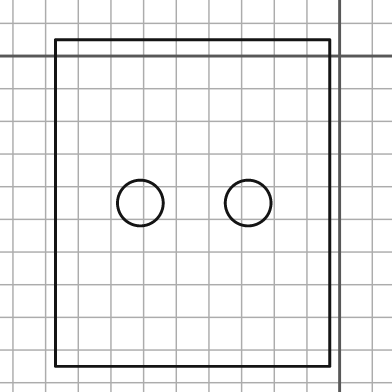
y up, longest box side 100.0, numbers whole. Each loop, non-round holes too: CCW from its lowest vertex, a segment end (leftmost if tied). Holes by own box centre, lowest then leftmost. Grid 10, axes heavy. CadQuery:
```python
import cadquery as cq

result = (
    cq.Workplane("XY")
    .moveTo(-87.0, -95.0)
    .lineTo(-3.0, -95.0)
    .lineTo(-3.0, 5.0)
    .lineTo(-87.0, 5.0)
    .close()
    .moveTo(-61.0, -45.0)
    .circle(7.0)
    .moveTo(-28.0, -45.0)
    .circle(7.0)
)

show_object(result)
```